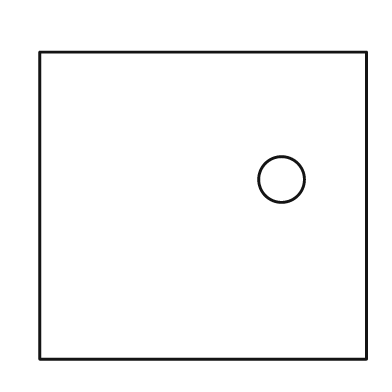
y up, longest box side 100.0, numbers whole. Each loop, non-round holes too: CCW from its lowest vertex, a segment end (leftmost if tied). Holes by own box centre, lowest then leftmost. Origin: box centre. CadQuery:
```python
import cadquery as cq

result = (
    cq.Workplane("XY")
    .moveTo(-50.0, -47.0)
    .lineTo(50.0, -47.0)
    .lineTo(50.0, 47.0)
    .lineTo(-50.0, 47.0)
    .close()
    .moveTo(24.0, 8.0)
    .circle(7.0)
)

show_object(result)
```